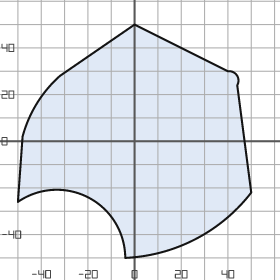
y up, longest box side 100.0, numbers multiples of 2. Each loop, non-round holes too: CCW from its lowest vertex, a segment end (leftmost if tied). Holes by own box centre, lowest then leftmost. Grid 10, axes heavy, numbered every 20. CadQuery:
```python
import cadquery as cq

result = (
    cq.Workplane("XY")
    .moveTo(-4.0, -50.0)
    .threePointArc((26.0, -42.0), (50.0, -22.0))
    .lineTo(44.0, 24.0)
    .threePointArc((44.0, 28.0), (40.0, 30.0))
    .lineTo(0.0, 50.0)
    .lineTo(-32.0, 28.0)
    .threePointArc((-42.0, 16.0), (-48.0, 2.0))
    .lineTo(-50.0, -26.0)
    .threePointArc((-20.0, -24.0), (-4.0, -50.0))
    .close()
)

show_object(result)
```